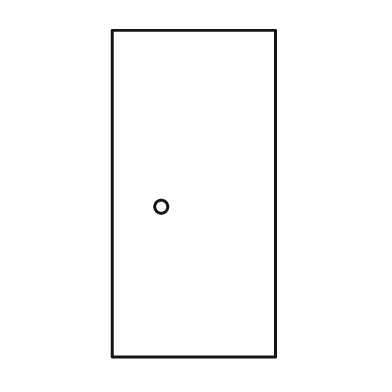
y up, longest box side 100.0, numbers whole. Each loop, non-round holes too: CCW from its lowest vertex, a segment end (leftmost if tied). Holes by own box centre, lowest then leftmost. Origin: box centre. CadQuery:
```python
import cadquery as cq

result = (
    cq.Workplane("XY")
    .moveTo(-25.0, -50.0)
    .lineTo(25.0, -50.0)
    .lineTo(25.0, 50.0)
    .lineTo(-25.0, 50.0)
    .close()
    .moveTo(-10.0, -4.0)
    .circle(2.0)
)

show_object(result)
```